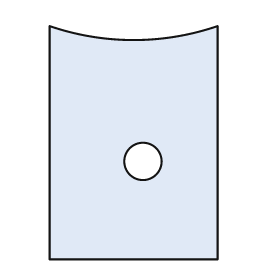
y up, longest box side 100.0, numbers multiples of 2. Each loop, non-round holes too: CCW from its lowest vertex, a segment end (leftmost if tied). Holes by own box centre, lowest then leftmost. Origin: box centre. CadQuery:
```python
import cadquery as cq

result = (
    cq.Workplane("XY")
    .moveTo(-36.0, -50.0)
    .lineTo(36.0, -50.0)
    .lineTo(36.0, 50.0)
    .threePointArc((0.0, 44.0), (-36.0, 50.0))
    .close()
    .moveTo(4.0, -8.0)
    .circle(8.0)
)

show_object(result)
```